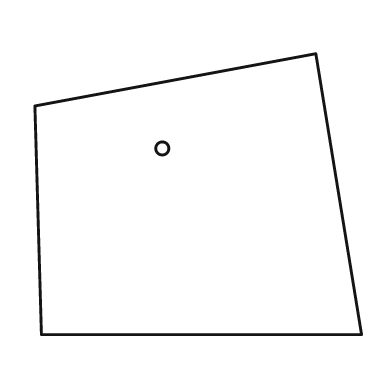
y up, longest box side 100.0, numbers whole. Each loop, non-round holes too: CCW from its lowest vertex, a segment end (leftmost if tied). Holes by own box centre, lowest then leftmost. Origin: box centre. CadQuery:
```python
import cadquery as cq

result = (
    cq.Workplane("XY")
    .moveTo(-48.0, -43.0)
    .lineTo(50.0, -43.0)
    .lineTo(36.0, 43.0)
    .lineTo(-50.0, 27.0)
    .close()
    .moveTo(-11.0, 14.0)
    .circle(2.0)
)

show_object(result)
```